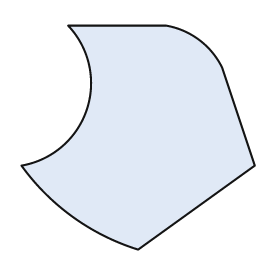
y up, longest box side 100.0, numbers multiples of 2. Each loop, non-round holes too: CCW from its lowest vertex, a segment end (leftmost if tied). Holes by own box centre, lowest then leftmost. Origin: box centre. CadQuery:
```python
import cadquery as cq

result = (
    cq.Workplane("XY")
    .moveTo(0.0, -48.0)
    .lineTo(50.0, -12.0)
    .lineTo(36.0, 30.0)
    .threePointArc((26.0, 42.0), (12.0, 48.0))
    .lineTo(-30.0, 48.0)
    .threePointArc((-22.0, 12.0), (-50.0, -12.0))
    .threePointArc((-28.0, -34.0), (0.0, -48.0))
    .close()
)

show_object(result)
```